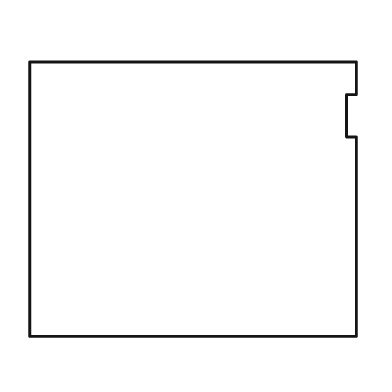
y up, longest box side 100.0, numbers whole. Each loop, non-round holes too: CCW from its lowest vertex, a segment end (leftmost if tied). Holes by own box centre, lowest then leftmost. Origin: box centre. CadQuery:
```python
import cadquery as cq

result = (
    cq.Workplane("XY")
    .moveTo(-50.0, -42.0)
    .lineTo(50.0, -42.0)
    .lineTo(50.0, 19.0)
    .lineTo(47.0, 19.0)
    .lineTo(47.0, 32.0)
    .lineTo(50.0, 32.0)
    .lineTo(50.0, 42.0)
    .lineTo(-50.0, 42.0)
    .close()
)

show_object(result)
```